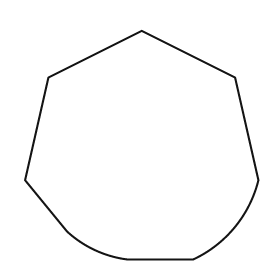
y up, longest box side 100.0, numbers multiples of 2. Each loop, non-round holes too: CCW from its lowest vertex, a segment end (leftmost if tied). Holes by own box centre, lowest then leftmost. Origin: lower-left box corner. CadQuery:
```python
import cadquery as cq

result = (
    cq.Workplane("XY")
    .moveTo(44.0, 0.0)
    .lineTo(72.0, 0.0)
    .threePointArc((90.0, 14.0), (100.0, 34.0))
    .lineTo(90.0, 78.0)
    .lineTo(50.0, 98.0)
    .lineTo(10.0, 78.0)
    .lineTo(0.0, 34.0)
    .lineTo(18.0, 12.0)
    .threePointArc((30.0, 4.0), (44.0, 0.0))
    .close()
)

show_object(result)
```